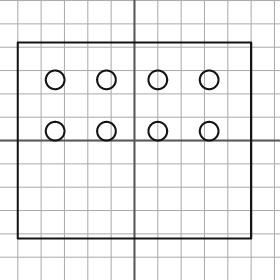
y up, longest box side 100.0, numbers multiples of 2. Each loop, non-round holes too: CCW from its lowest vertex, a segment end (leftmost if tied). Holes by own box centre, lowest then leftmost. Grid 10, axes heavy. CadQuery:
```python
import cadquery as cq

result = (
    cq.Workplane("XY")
    .moveTo(-50.0, -42.0)
    .lineTo(50.0, -42.0)
    .lineTo(50.0, 42.0)
    .lineTo(-50.0, 42.0)
    .close()
    .moveTo(-34.0, 4.0)
    .circle(4.0)
    .moveTo(-12.0, 4.0)
    .circle(4.0)
    .moveTo(10.0, 4.0)
    .circle(4.0)
    .moveTo(32.0, 4.0)
    .circle(4.0)
    .moveTo(-34.0, 26.0)
    .circle(4.0)
    .moveTo(-12.0, 26.0)
    .circle(4.0)
    .moveTo(10.0, 26.0)
    .circle(4.0)
    .moveTo(32.0, 26.0)
    .circle(4.0)
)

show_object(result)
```